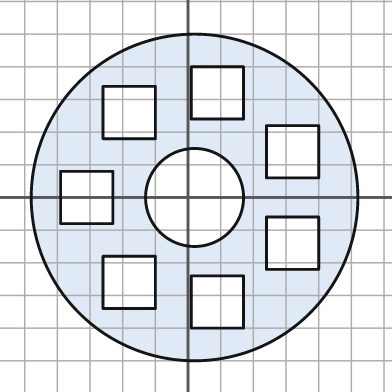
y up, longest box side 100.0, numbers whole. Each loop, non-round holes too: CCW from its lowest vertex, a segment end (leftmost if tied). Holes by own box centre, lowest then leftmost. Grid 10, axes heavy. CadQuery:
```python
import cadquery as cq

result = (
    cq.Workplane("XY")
    .moveTo(2.0, 0.0)
    .circle(50.0)
    .moveTo(1.0, -40.0)
    .lineTo(17.0, -40.0)
    .lineTo(17.0, -24.0)
    .lineTo(1.0, -24.0)
    .close()
    .moveTo(-26.0, -34.0)
    .lineTo(-10.0, -34.0)
    .lineTo(-10.0, -18.0)
    .lineTo(-26.0, -18.0)
    .close()
    .moveTo(24.0, -22.0)
    .lineTo(40.0, -22.0)
    .lineTo(40.0, -6.0)
    .lineTo(24.0, -6.0)
    .close()
    .moveTo(-39.0, -8.0)
    .lineTo(-23.0, -8.0)
    .lineTo(-23.0, 8.0)
    .lineTo(-39.0, 8.0)
    .close()
    .moveTo(2.0, 0.0)
    .circle(15.0)
    .moveTo(24.0, 6.0)
    .lineTo(40.0, 6.0)
    .lineTo(40.0, 22.0)
    .lineTo(24.0, 22.0)
    .close()
    .moveTo(-26.0, 18.0)
    .lineTo(-10.0, 18.0)
    .lineTo(-10.0, 34.0)
    .lineTo(-26.0, 34.0)
    .close()
    .moveTo(1.0, 24.0)
    .lineTo(17.0, 24.0)
    .lineTo(17.0, 40.0)
    .lineTo(1.0, 40.0)
    .close()
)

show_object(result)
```